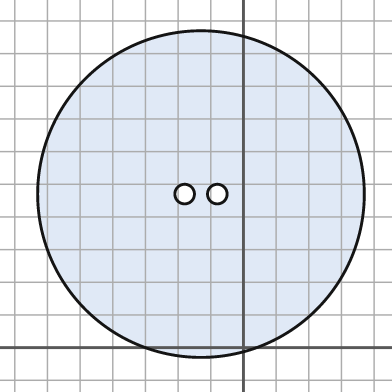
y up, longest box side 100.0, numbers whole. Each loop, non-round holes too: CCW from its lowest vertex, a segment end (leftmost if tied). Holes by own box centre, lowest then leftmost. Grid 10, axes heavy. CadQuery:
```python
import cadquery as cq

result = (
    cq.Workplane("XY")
    .moveTo(-13.0, 47.0)
    .circle(50.0)
    .moveTo(-18.0, 47.0)
    .circle(3.0)
    .moveTo(-8.0, 47.0)
    .circle(3.0)
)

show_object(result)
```